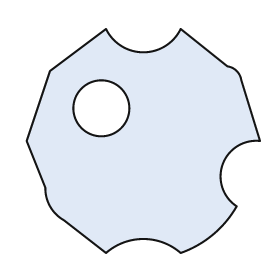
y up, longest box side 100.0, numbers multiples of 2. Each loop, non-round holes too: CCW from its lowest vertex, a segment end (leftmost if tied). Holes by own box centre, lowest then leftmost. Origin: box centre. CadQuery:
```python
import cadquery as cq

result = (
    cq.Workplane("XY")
    .moveTo(-16.0, -48.0)
    .threePointArc((0.0, -42.0), (16.0, -48.0))
    .threePointArc((30.0, -40.0), (40.0, -28.0))
    .threePointArc((34.0, -10.0), (50.0, 0.0))
    .lineTo(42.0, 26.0)
    .threePointArc((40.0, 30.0), (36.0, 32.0))
    .lineTo(16.0, 48.0)
    .threePointArc((0.0, 38.0), (-16.0, 48.0))
    .lineTo(-40.0, 30.0)
    .lineTo(-50.0, 0.0)
    .lineTo(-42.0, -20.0)
    .threePointArc((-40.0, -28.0), (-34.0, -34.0))
    .close()
    .moveTo(-18.0, 14.0)
    .circle(12.0)
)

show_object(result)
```